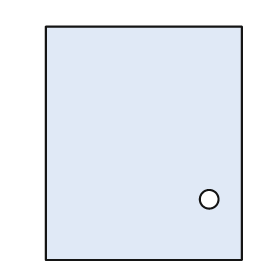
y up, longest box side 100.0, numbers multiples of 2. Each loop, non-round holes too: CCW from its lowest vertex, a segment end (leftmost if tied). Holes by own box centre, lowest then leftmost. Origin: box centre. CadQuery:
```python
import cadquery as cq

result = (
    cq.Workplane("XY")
    .moveTo(-42.0, -50.0)
    .lineTo(42.0, -50.0)
    .lineTo(42.0, 50.0)
    .lineTo(-42.0, 50.0)
    .close()
    .moveTo(28.0, -24.0)
    .circle(4.0)
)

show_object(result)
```